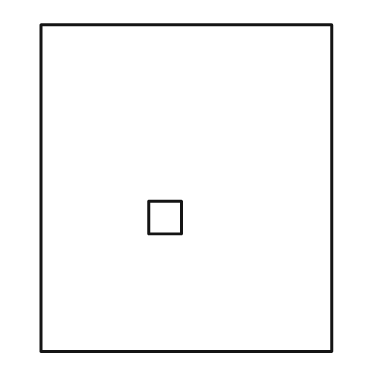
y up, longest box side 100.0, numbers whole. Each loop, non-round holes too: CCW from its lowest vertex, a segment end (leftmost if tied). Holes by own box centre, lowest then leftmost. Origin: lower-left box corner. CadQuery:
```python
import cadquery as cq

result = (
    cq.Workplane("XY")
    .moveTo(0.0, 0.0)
    .lineTo(89.0, 0.0)
    .lineTo(89.0, 100.0)
    .lineTo(0.0, 100.0)
    .close()
    .moveTo(33.0, 36.0)
    .lineTo(43.0, 36.0)
    .lineTo(43.0, 46.0)
    .lineTo(33.0, 46.0)
    .close()
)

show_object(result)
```